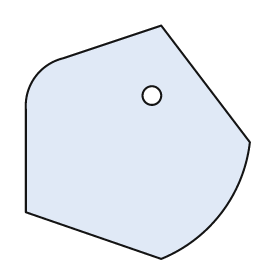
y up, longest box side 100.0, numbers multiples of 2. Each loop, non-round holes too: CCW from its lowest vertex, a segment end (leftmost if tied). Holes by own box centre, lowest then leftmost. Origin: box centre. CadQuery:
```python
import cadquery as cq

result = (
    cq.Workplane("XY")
    .moveTo(10.0, -50.0)
    .threePointArc((36.0, -30.0), (48.0, 0.0))
    .lineTo(10.0, 50.0)
    .lineTo(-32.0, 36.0)
    .threePointArc((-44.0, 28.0), (-48.0, 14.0))
    .lineTo(-48.0, -30.0)
    .close()
    .moveTo(6.0, 20.0)
    .circle(4.0)
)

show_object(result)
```